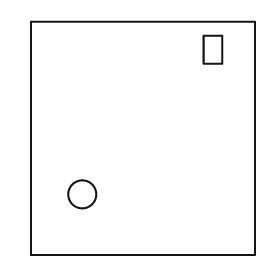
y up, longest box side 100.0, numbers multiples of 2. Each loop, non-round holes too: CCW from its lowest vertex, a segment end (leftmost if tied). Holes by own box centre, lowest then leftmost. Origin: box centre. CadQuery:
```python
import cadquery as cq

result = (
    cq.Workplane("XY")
    .moveTo(-48.0, -50.0)
    .lineTo(48.0, -50.0)
    .lineTo(48.0, 50.0)
    .lineTo(-48.0, 50.0)
    .close()
    .moveTo(-26.0, -24.0)
    .circle(6.0)
    .moveTo(26.0, 32.0)
    .lineTo(34.0, 32.0)
    .lineTo(34.0, 44.0)
    .lineTo(26.0, 44.0)
    .close()
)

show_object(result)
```